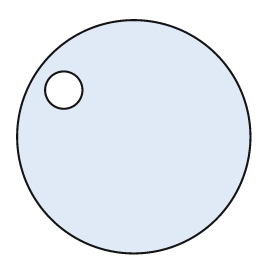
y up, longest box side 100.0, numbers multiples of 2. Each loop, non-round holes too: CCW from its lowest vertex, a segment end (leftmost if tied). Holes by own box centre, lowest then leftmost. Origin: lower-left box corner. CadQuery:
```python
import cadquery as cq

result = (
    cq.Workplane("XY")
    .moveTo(50.0, 50.0)
    .circle(50.0)
    .moveTo(20.0, 70.0)
    .circle(8.0)
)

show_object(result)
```